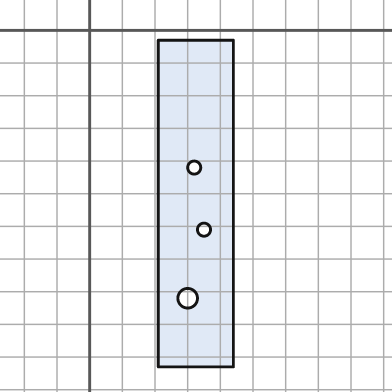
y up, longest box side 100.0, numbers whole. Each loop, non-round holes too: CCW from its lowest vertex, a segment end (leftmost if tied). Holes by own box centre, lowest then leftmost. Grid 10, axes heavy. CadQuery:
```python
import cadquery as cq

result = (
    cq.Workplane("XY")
    .moveTo(21.0, -103.0)
    .lineTo(44.0, -103.0)
    .lineTo(44.0, -3.0)
    .lineTo(21.0, -3.0)
    .close()
    .moveTo(30.0, -82.0)
    .circle(3.0)
    .moveTo(35.0, -61.0)
    .circle(2.0)
    .moveTo(32.0, -42.0)
    .circle(2.0)
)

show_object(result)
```